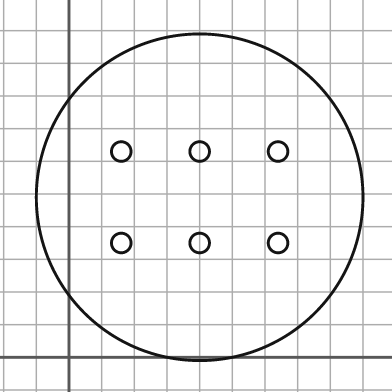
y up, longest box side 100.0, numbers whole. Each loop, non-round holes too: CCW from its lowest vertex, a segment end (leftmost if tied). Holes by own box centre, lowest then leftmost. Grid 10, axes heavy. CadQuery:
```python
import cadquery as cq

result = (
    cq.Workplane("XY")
    .moveTo(40.0, 49.0)
    .circle(50.0)
    .moveTo(16.0, 35.0)
    .circle(3.0)
    .moveTo(40.0, 35.0)
    .circle(3.0)
    .moveTo(64.0, 35.0)
    .circle(3.0)
    .moveTo(16.0, 63.0)
    .circle(3.0)
    .moveTo(40.0, 63.0)
    .circle(3.0)
    .moveTo(64.0, 63.0)
    .circle(3.0)
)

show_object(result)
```